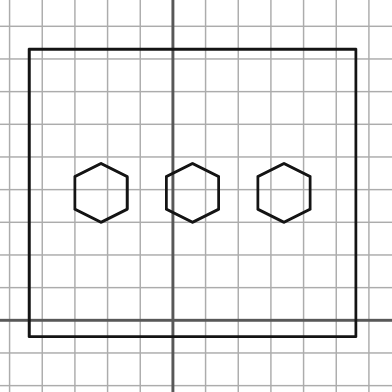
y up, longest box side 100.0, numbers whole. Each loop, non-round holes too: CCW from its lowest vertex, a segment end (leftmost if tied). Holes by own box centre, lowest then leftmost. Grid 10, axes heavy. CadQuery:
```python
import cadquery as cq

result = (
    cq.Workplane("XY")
    .moveTo(-44.0, -5.0)
    .lineTo(56.0, -5.0)
    .lineTo(56.0, 83.0)
    .lineTo(-44.0, 83.0)
    .close()
    .moveTo(-22.0, 30.0)
    .lineTo(-14.0, 34.0)
    .lineTo(-14.0, 44.0)
    .lineTo(-22.0, 48.0)
    .lineTo(-30.0, 44.0)
    .lineTo(-30.0, 34.0)
    .close()
    .moveTo(6.0, 30.0)
    .lineTo(14.0, 34.0)
    .lineTo(14.0, 44.0)
    .lineTo(6.0, 48.0)
    .lineTo(-2.0, 44.0)
    .lineTo(-2.0, 34.0)
    .close()
    .moveTo(34.0, 30.0)
    .lineTo(42.0, 34.0)
    .lineTo(42.0, 44.0)
    .lineTo(34.0, 48.0)
    .lineTo(26.0, 44.0)
    .lineTo(26.0, 34.0)
    .close()
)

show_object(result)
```